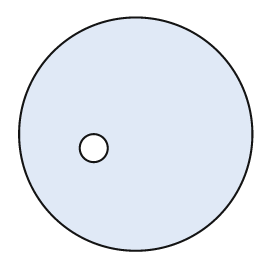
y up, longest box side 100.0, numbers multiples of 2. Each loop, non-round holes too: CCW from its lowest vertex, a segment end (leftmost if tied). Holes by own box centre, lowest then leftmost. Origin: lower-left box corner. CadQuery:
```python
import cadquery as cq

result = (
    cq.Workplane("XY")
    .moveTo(50.0, 50.0)
    .circle(50.0)
    .moveTo(32.0, 44.0)
    .circle(6.0)
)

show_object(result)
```